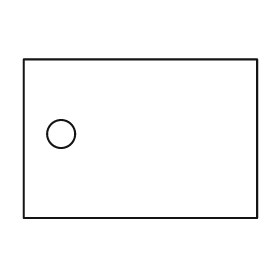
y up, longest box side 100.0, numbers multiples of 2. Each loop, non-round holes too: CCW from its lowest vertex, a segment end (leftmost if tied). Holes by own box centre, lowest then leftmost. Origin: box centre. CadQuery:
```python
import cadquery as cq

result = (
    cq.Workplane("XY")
    .moveTo(-50.0, -34.0)
    .lineTo(50.0, -34.0)
    .lineTo(50.0, 34.0)
    .lineTo(-50.0, 34.0)
    .close()
    .moveTo(-34.0, 2.0)
    .circle(6.0)
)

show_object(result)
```